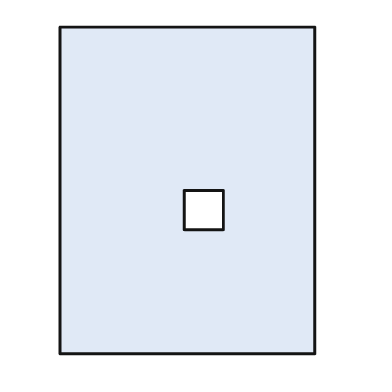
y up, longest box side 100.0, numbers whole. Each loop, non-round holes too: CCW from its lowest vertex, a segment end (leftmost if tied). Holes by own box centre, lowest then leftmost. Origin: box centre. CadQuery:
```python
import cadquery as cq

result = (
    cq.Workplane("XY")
    .moveTo(-39.0, -50.0)
    .lineTo(39.0, -50.0)
    .lineTo(39.0, 50.0)
    .lineTo(-39.0, 50.0)
    .close()
    .moveTo(-1.0, -12.0)
    .lineTo(11.0, -12.0)
    .lineTo(11.0, 0.0)
    .lineTo(-1.0, 0.0)
    .close()
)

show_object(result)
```